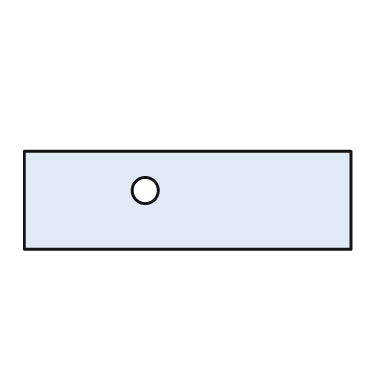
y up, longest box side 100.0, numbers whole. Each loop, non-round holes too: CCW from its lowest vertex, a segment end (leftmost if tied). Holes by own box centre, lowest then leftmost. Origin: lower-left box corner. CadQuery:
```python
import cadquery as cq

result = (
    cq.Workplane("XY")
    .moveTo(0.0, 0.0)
    .lineTo(100.0, 0.0)
    .lineTo(100.0, 30.0)
    .lineTo(0.0, 30.0)
    .close()
    .moveTo(37.0, 18.0)
    .circle(4.0)
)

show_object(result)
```